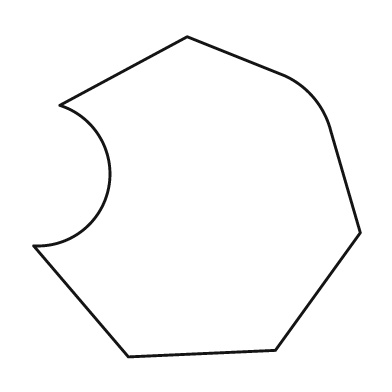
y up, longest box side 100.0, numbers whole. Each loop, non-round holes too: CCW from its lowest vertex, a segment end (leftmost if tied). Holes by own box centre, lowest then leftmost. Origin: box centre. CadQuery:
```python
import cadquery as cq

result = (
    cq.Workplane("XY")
    .moveTo(-21.0, -49.0)
    .lineTo(24.0, -47.0)
    .lineTo(50.0, -11.0)
    .lineTo(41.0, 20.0)
    .threePointArc((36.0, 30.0), (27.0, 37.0))
    .lineTo(-3.0, 49.0)
    .lineTo(-42.0, 28.0)
    .threePointArc((-27.0, 3.0), (-50.0, -15.0))
    .close()
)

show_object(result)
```